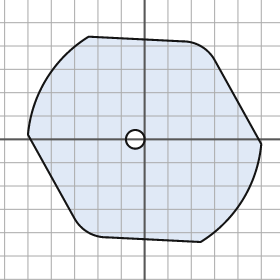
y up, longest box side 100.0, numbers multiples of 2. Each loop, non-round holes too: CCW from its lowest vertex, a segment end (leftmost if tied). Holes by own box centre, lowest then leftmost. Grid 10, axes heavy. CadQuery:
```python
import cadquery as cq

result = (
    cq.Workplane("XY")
    .moveTo(24.0, -44.0)
    .threePointArc((42.0, -26.0), (50.0, -2.0))
    .lineTo(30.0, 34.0)
    .threePointArc((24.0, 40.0), (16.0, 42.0))
    .lineTo(-24.0, 44.0)
    .threePointArc((-42.0, 26.0), (-50.0, 2.0))
    .lineTo(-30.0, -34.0)
    .threePointArc((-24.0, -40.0), (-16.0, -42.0))
    .close()
    .moveTo(-4.0, 0.0)
    .circle(4.0)
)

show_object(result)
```